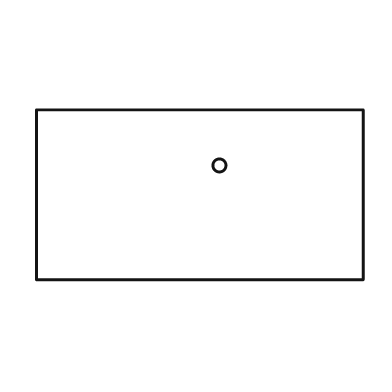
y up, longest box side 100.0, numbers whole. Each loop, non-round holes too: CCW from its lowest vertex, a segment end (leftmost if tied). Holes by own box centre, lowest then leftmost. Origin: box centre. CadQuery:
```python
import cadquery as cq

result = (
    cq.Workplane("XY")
    .moveTo(-50.0, -26.0)
    .lineTo(50.0, -26.0)
    .lineTo(50.0, 26.0)
    .lineTo(-50.0, 26.0)
    .close()
    .moveTo(6.0, 9.0)
    .circle(2.0)
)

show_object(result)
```